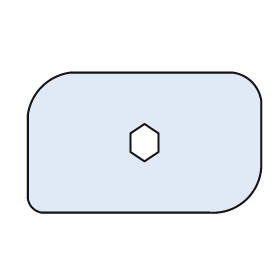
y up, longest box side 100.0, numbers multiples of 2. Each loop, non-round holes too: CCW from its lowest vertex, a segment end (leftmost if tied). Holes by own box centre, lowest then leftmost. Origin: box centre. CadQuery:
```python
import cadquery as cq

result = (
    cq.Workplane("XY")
    .moveTo(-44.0, -30.0)
    .lineTo(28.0, -30.0)
    .threePointArc((44.0, -24.0), (50.0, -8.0))
    .lineTo(50.0, 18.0)
    .threePointArc((46.0, 26.0), (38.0, 30.0))
    .lineTo(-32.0, 30.0)
    .threePointArc((-44.0, 24.0), (-50.0, 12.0))
    .lineTo(-50.0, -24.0)
    .threePointArc((-48.0, -28.0), (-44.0, -30.0))
    .close()
    .moveTo(0.0, -8.0)
    .lineTo(6.0, -4.0)
    .lineTo(6.0, 4.0)
    .lineTo(0.0, 8.0)
    .lineTo(-6.0, 4.0)
    .lineTo(-6.0, -4.0)
    .close()
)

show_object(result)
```